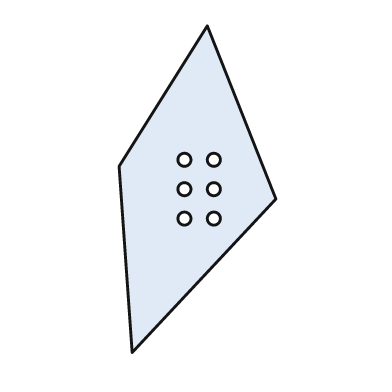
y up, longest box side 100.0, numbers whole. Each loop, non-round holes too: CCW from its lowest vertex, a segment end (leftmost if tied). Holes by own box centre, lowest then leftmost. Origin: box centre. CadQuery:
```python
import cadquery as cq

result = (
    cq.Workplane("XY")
    .moveTo(-20.0, -50.0)
    .lineTo(24.0, -3.0)
    .lineTo(3.0, 50.0)
    .lineTo(-24.0, 7.0)
    .close()
    .moveTo(-4.0, -9.0)
    .circle(2.0)
    .moveTo(5.0, -9.0)
    .circle(2.0)
    .moveTo(-4.0, 0.0)
    .circle(2.0)
    .moveTo(5.0, 0.0)
    .circle(2.0)
    .moveTo(-4.0, 9.0)
    .circle(2.0)
    .moveTo(5.0, 9.0)
    .circle(2.0)
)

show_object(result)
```